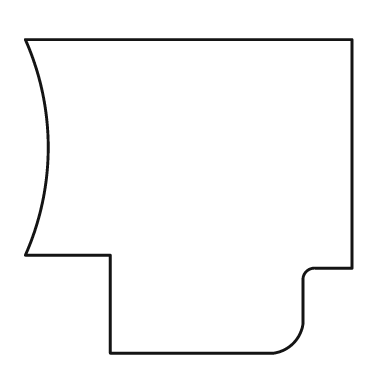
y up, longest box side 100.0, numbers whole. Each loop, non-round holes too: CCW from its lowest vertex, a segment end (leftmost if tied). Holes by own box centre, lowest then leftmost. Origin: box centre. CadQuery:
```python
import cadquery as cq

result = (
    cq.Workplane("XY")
    .moveTo(-24.0, -48.0)
    .lineTo(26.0, -48.0)
    .threePointArc((32.0, -45.0), (35.0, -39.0))
    .lineTo(35.0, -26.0)
    .threePointArc((36.0, -23.0), (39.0, -22.0))
    .lineTo(50.0, -22.0)
    .lineTo(50.0, 48.0)
    .lineTo(-50.0, 48.0)
    .threePointArc((-43.0, 15.0), (-50.0, -18.0))
    .lineTo(-24.0, -18.0)
    .close()
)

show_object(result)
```